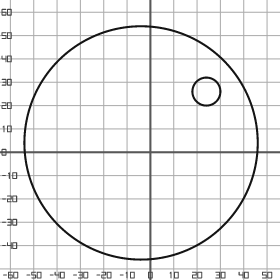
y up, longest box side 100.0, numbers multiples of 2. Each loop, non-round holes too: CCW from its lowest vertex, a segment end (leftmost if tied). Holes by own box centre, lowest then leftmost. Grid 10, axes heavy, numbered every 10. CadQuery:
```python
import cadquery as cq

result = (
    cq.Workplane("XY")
    .moveTo(-4.0, 4.0)
    .circle(50.0)
    .moveTo(24.0, 26.0)
    .circle(6.0)
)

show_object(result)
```